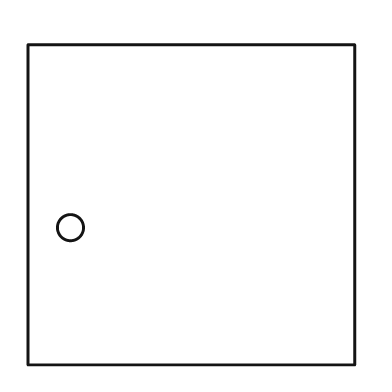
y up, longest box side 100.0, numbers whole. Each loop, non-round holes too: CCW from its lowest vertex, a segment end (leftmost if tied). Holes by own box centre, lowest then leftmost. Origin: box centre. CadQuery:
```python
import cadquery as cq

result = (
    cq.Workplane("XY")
    .moveTo(-50.0, -49.0)
    .lineTo(50.0, -49.0)
    .lineTo(50.0, 49.0)
    .lineTo(-50.0, 49.0)
    .close()
    .moveTo(-37.0, -7.0)
    .circle(4.0)
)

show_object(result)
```